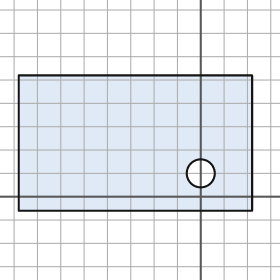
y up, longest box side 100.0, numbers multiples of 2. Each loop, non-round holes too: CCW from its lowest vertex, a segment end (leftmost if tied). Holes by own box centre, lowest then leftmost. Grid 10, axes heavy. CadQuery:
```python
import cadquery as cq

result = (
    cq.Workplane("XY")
    .moveTo(-78.0, -6.0)
    .lineTo(22.0, -6.0)
    .lineTo(22.0, 52.0)
    .lineTo(-78.0, 52.0)
    .close()
    .moveTo(0.0, 10.0)
    .circle(6.0)
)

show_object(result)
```